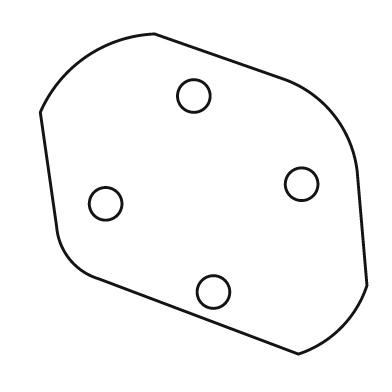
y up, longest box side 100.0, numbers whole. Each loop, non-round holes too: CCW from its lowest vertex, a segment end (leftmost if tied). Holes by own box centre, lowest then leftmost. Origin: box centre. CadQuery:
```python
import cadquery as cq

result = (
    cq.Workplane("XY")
    .moveTo(29.0, -49.0)
    .threePointArc((42.0, -41.0), (50.0, -28.0))
    .lineTo(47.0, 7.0)
    .threePointArc((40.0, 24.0), (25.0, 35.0))
    .lineTo(-15.0, 49.0)
    .threePointArc((-36.0, 42.0), (-50.0, 25.0))
    .lineTo(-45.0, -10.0)
    .threePointArc((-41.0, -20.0), (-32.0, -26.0))
    .close()
    .moveTo(3.0, -30.0)
    .circle(5.0)
    .moveTo(-30.0, -3.0)
    .circle(5.0)
    .moveTo(30.0, 3.0)
    .circle(5.0)
    .moveTo(-3.0, 30.0)
    .circle(5.0)
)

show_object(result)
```